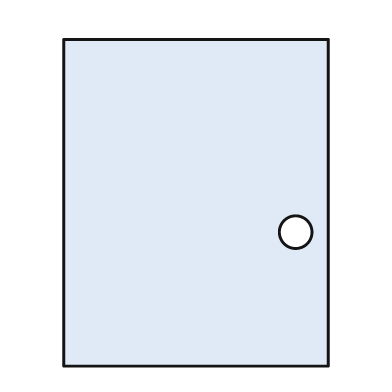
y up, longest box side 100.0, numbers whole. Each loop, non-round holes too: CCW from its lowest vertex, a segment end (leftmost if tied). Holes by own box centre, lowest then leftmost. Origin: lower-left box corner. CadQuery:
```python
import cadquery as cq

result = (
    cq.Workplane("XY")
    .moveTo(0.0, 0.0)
    .lineTo(81.0, 0.0)
    .lineTo(81.0, 100.0)
    .lineTo(0.0, 100.0)
    .close()
    .moveTo(71.0, 41.0)
    .circle(5.0)
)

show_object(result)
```